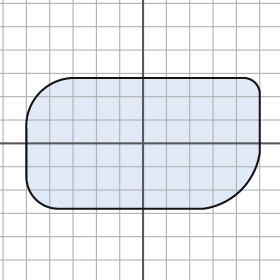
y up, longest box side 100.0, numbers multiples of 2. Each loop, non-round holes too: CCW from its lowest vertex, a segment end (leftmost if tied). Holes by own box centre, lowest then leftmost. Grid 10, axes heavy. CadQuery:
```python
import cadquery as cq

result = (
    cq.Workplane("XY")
    .moveTo(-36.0, -28.0)
    .lineTo(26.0, -28.0)
    .threePointArc((42.0, -20.0), (50.0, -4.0))
    .lineTo(50.0, 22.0)
    .threePointArc((48.0, 26.0), (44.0, 28.0))
    .lineTo(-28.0, 28.0)
    .threePointArc((-44.0, 22.0), (-50.0, 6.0))
    .lineTo(-50.0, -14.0)
    .threePointArc((-46.0, -24.0), (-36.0, -28.0))
    .close()
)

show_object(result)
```